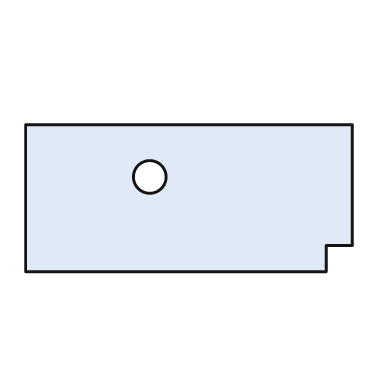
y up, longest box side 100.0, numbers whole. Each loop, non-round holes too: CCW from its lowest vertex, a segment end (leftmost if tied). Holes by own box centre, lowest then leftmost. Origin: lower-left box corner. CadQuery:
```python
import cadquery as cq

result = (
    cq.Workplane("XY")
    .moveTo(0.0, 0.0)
    .lineTo(92.0, 0.0)
    .lineTo(92.0, 8.0)
    .lineTo(100.0, 8.0)
    .lineTo(100.0, 45.0)
    .lineTo(0.0, 45.0)
    .close()
    .moveTo(38.0, 29.0)
    .circle(5.0)
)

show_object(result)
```